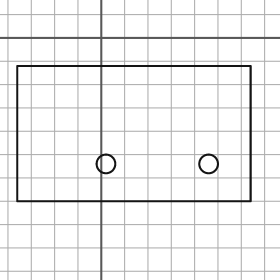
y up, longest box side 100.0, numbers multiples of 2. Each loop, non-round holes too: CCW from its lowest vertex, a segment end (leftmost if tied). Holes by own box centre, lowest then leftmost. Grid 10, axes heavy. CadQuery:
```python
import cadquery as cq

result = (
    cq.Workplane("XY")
    .moveTo(-36.0, -70.0)
    .lineTo(64.0, -70.0)
    .lineTo(64.0, -12.0)
    .lineTo(-36.0, -12.0)
    .close()
    .moveTo(2.0, -54.0)
    .circle(4.0)
    .moveTo(46.0, -54.0)
    .circle(4.0)
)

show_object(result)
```